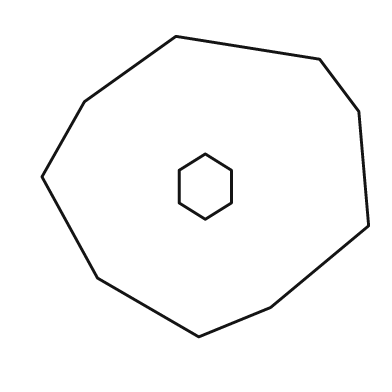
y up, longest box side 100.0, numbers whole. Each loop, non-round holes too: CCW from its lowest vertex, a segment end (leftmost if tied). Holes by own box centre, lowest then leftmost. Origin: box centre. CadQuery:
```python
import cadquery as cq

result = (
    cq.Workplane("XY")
    .moveTo(-2.0, -46.0)
    .lineTo(20.0, -37.0)
    .lineTo(50.0, -12.0)
    .lineTo(47.0, 23.0)
    .lineTo(35.0, 39.0)
    .lineTo(-9.0, 46.0)
    .lineTo(-37.0, 26.0)
    .lineTo(-50.0, 3.0)
    .lineTo(-33.0, -28.0)
    .close()
    .moveTo(0.0, -10.0)
    .lineTo(8.0, -5.0)
    .lineTo(8.0, 5.0)
    .lineTo(0.0, 10.0)
    .lineTo(-8.0, 5.0)
    .lineTo(-8.0, -5.0)
    .close()
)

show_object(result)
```